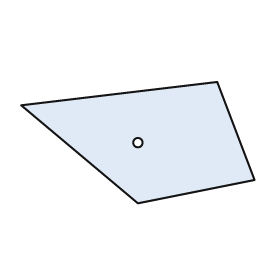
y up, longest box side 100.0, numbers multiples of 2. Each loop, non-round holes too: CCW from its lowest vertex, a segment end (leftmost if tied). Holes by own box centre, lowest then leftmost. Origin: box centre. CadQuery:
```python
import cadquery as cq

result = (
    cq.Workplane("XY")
    .moveTo(0.0, -26.0)
    .lineTo(50.0, -16.0)
    .lineTo(34.0, 26.0)
    .lineTo(-50.0, 16.0)
    .close()
    .moveTo(0.0, 0.0)
    .circle(2.0)
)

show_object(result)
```